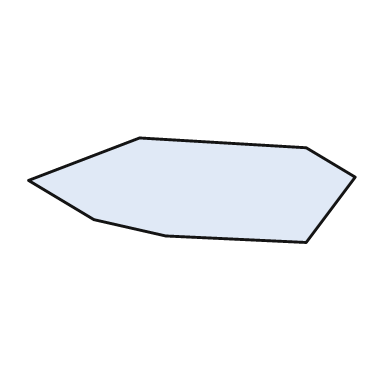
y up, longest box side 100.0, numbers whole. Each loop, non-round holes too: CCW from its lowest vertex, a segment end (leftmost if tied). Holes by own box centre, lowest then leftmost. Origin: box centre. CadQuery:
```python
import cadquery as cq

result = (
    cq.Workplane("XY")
    .moveTo(35.0, -16.0)
    .lineTo(50.0, 4.0)
    .lineTo(35.0, 13.0)
    .lineTo(-16.0, 16.0)
    .lineTo(-50.0, 3.0)
    .lineTo(-30.0, -9.0)
    .lineTo(-8.0, -14.0)
    .close()
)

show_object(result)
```